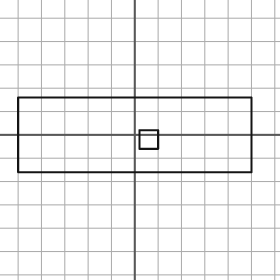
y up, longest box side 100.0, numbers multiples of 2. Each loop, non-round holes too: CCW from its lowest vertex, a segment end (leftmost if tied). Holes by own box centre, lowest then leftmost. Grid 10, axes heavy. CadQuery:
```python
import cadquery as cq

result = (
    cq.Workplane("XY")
    .moveTo(-50.0, -16.0)
    .lineTo(50.0, -16.0)
    .lineTo(50.0, 16.0)
    .lineTo(-50.0, 16.0)
    .close()
    .moveTo(2.0, -6.0)
    .lineTo(10.0, -6.0)
    .lineTo(10.0, 2.0)
    .lineTo(2.0, 2.0)
    .close()
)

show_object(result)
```